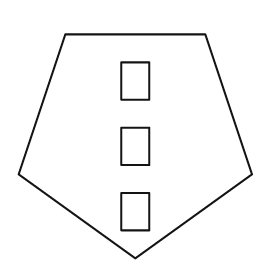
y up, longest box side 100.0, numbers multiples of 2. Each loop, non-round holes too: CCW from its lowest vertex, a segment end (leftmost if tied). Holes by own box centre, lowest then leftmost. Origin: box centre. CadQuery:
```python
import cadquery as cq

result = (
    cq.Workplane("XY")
    .moveTo(0.0, -48.0)
    .lineTo(50.0, -12.0)
    .lineTo(30.0, 48.0)
    .lineTo(-30.0, 48.0)
    .lineTo(-50.0, -12.0)
    .close()
    .moveTo(-6.0, -36.0)
    .lineTo(6.0, -36.0)
    .lineTo(6.0, -20.0)
    .lineTo(-6.0, -20.0)
    .close()
    .moveTo(-6.0, -8.0)
    .lineTo(6.0, -8.0)
    .lineTo(6.0, 8.0)
    .lineTo(-6.0, 8.0)
    .close()
    .moveTo(-6.0, 20.0)
    .lineTo(6.0, 20.0)
    .lineTo(6.0, 36.0)
    .lineTo(-6.0, 36.0)
    .close()
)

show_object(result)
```